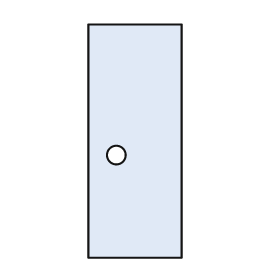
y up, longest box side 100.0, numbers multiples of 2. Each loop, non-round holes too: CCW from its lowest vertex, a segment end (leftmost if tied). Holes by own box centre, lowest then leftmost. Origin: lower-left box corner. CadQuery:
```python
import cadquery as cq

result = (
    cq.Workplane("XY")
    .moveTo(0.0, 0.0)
    .lineTo(40.0, 0.0)
    .lineTo(40.0, 100.0)
    .lineTo(0.0, 100.0)
    .close()
    .moveTo(12.0, 44.0)
    .circle(4.0)
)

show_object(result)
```